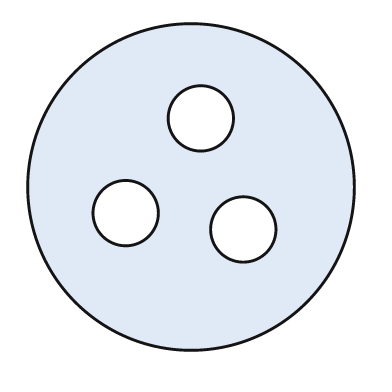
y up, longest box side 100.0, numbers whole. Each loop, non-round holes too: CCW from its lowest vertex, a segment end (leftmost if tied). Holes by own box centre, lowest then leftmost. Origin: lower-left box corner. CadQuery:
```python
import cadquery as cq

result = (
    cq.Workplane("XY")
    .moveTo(50.0, 50.0)
    .circle(50.0)
    .moveTo(66.0, 37.0)
    .circle(10.0)
    .moveTo(30.0, 42.0)
    .circle(10.0)
    .moveTo(53.0, 71.0)
    .circle(10.0)
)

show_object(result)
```